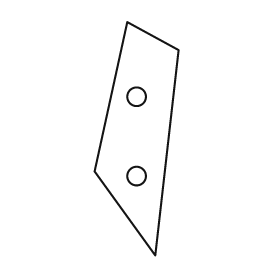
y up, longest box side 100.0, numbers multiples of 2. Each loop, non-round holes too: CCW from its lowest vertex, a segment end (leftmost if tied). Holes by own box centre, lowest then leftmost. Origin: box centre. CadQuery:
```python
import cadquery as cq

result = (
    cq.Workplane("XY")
    .moveTo(8.0, -50.0)
    .lineTo(18.0, 38.0)
    .lineTo(-4.0, 50.0)
    .lineTo(-18.0, -14.0)
    .close()
    .moveTo(0.0, -16.0)
    .circle(4.0)
    .moveTo(0.0, 18.0)
    .circle(4.0)
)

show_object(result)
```